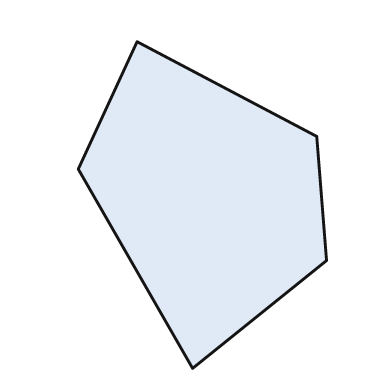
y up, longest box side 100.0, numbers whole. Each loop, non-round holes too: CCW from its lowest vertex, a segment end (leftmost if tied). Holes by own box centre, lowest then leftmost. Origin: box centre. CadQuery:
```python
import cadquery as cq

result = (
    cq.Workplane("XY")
    .moveTo(-3.0, -50.0)
    .lineTo(38.0, -17.0)
    .lineTo(35.0, 21.0)
    .lineTo(-20.0, 50.0)
    .lineTo(-38.0, 11.0)
    .close()
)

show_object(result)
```